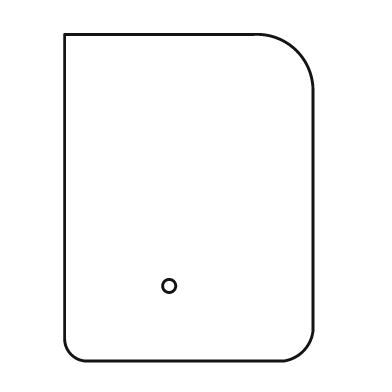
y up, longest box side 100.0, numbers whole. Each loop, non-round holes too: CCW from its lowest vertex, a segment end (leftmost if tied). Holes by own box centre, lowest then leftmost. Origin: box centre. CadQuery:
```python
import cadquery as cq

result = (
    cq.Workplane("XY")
    .moveTo(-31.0, -50.0)
    .lineTo(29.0, -50.0)
    .threePointArc((35.0, -47.0), (38.0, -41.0))
    .lineTo(38.0, 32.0)
    .threePointArc((33.0, 45.0), (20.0, 50.0))
    .lineTo(-38.0, 50.0)
    .lineTo(-38.0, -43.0)
    .threePointArc((-36.0, -48.0), (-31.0, -50.0))
    .close()
    .moveTo(-6.0, -27.0)
    .circle(2.0)
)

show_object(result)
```